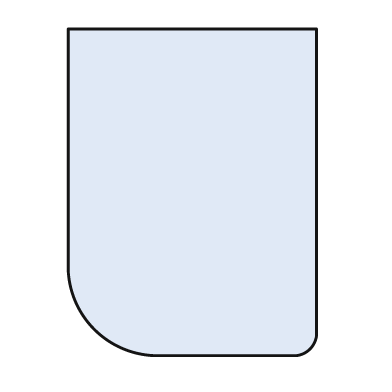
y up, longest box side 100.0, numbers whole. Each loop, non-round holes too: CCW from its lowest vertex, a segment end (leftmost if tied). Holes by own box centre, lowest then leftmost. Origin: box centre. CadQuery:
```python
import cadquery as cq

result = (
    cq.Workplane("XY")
    .moveTo(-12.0, -50.0)
    .lineTo(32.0, -50.0)
    .threePointArc((36.0, -48.0), (38.0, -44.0))
    .lineTo(38.0, 50.0)
    .lineTo(-38.0, 50.0)
    .lineTo(-38.0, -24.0)
    .threePointArc((-30.0, -42.0), (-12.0, -50.0))
    .close()
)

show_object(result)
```